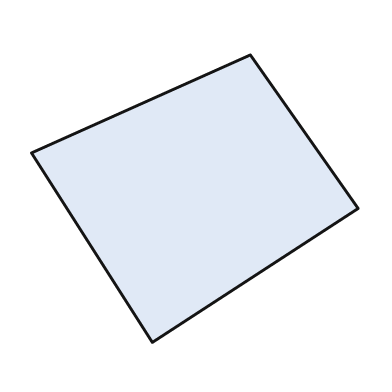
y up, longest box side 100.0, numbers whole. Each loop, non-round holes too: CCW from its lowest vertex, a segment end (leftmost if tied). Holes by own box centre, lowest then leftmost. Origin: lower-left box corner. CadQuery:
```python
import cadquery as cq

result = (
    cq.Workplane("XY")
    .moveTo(37.0, 0.0)
    .lineTo(100.0, 41.0)
    .lineTo(67.0, 88.0)
    .lineTo(0.0, 58.0)
    .close()
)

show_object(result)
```